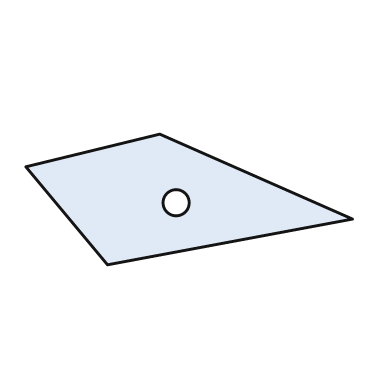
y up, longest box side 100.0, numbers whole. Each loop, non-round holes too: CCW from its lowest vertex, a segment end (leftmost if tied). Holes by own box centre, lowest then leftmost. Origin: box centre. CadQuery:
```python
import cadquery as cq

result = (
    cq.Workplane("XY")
    .moveTo(-25.0, -20.0)
    .lineTo(50.0, -6.0)
    .lineTo(-9.0, 20.0)
    .lineTo(-50.0, 10.0)
    .close()
    .moveTo(-4.0, -1.0)
    .circle(4.0)
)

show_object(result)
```